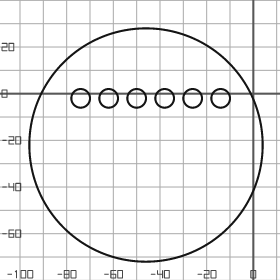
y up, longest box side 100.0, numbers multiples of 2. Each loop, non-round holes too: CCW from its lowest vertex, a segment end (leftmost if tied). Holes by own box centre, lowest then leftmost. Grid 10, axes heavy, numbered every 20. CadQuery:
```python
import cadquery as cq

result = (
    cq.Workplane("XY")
    .moveTo(-46.0, -22.0)
    .circle(50.0)
    .moveTo(-74.0, -2.0)
    .circle(4.0)
    .moveTo(-62.0, -2.0)
    .circle(4.0)
    .moveTo(-50.0, -2.0)
    .circle(4.0)
    .moveTo(-38.0, -2.0)
    .circle(4.0)
    .moveTo(-26.0, -2.0)
    .circle(4.0)
    .moveTo(-14.0, -2.0)
    .circle(4.0)
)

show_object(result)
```